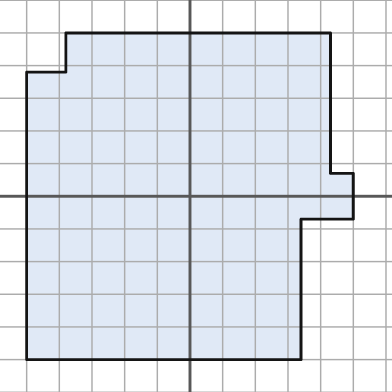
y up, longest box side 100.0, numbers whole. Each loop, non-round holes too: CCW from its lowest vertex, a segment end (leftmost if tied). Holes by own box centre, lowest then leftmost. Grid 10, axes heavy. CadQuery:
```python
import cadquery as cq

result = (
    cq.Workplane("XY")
    .moveTo(-50.0, -50.0)
    .lineTo(34.0, -50.0)
    .lineTo(34.0, -7.0)
    .lineTo(50.0, -7.0)
    .lineTo(50.0, 7.0)
    .lineTo(43.0, 7.0)
    .lineTo(43.0, 50.0)
    .lineTo(-38.0, 50.0)
    .lineTo(-38.0, 38.0)
    .lineTo(-50.0, 38.0)
    .close()
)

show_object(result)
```